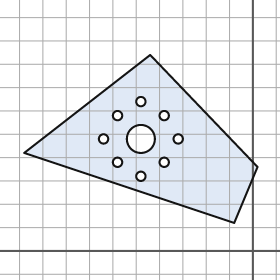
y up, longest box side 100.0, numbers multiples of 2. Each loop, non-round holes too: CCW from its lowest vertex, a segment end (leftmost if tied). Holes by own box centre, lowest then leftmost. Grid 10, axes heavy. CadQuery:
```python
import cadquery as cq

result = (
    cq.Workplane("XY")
    .moveTo(-8.0, 12.0)
    .lineTo(2.0, 36.0)
    .lineTo(-44.0, 84.0)
    .lineTo(-98.0, 42.0)
    .close()
    .moveTo(-48.0, 32.0)
    .circle(2.0)
    .moveTo(-58.0, 38.0)
    .circle(2.0)
    .moveTo(-38.0, 38.0)
    .circle(2.0)
    .moveTo(-64.0, 48.0)
    .circle(2.0)
    .moveTo(-48.0, 48.0)
    .circle(6.0)
    .moveTo(-32.0, 48.0)
    .circle(2.0)
    .moveTo(-58.0, 58.0)
    .circle(2.0)
    .moveTo(-38.0, 58.0)
    .circle(2.0)
    .moveTo(-48.0, 64.0)
    .circle(2.0)
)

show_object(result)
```